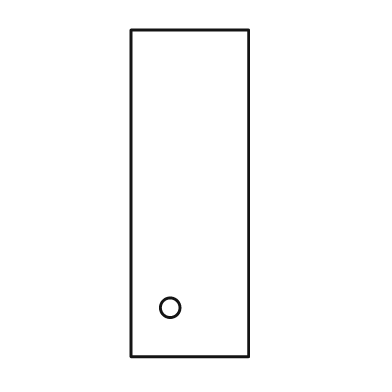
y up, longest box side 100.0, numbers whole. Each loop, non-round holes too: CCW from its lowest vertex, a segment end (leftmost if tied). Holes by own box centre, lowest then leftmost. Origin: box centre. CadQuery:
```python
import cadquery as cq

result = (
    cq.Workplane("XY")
    .moveTo(-18.0, -50.0)
    .lineTo(18.0, -50.0)
    .lineTo(18.0, 50.0)
    .lineTo(-18.0, 50.0)
    .close()
    .moveTo(-6.0, -35.0)
    .circle(3.0)
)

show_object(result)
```